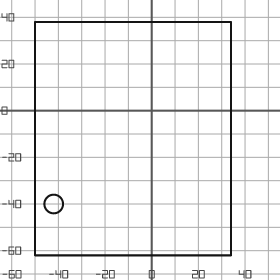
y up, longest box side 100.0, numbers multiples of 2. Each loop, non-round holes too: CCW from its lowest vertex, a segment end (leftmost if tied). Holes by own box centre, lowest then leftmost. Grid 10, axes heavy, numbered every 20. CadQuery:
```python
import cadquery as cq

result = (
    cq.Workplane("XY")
    .moveTo(-50.0, -62.0)
    .lineTo(34.0, -62.0)
    .lineTo(34.0, 38.0)
    .lineTo(-50.0, 38.0)
    .close()
    .moveTo(-42.0, -40.0)
    .circle(4.0)
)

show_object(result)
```